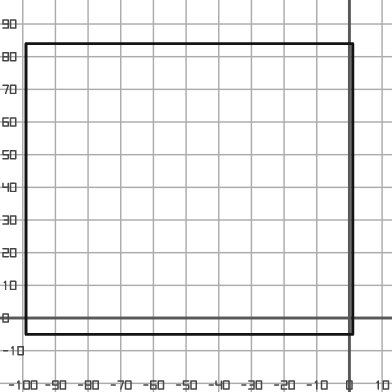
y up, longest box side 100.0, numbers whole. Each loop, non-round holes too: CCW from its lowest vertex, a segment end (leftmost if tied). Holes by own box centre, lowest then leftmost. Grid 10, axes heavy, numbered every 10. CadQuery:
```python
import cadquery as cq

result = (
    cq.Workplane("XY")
    .moveTo(-99.0, -5.0)
    .lineTo(1.0, -5.0)
    .lineTo(1.0, 84.0)
    .lineTo(-99.0, 84.0)
    .close()
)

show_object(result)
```